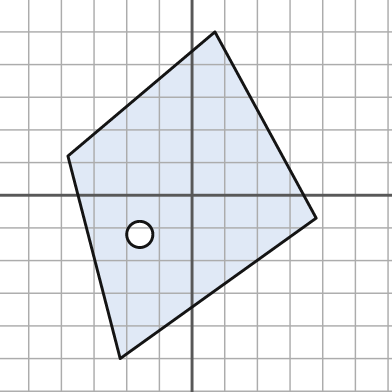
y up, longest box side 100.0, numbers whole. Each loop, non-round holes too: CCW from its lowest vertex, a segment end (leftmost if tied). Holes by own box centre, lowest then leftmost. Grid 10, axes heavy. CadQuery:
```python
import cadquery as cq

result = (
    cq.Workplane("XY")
    .moveTo(-22.0, -50.0)
    .lineTo(38.0, -7.0)
    .lineTo(7.0, 50.0)
    .lineTo(-38.0, 12.0)
    .close()
    .moveTo(-16.0, -12.0)
    .circle(4.0)
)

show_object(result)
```